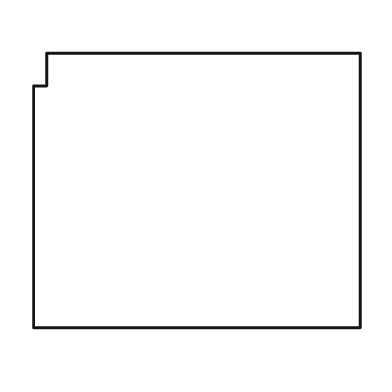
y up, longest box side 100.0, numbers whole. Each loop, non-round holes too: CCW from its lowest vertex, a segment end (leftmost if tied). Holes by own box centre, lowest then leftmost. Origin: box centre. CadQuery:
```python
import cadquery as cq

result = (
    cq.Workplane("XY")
    .moveTo(-50.0, -42.0)
    .lineTo(50.0, -42.0)
    .lineTo(50.0, 42.0)
    .lineTo(-46.0, 42.0)
    .lineTo(-46.0, 32.0)
    .lineTo(-50.0, 32.0)
    .close()
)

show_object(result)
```